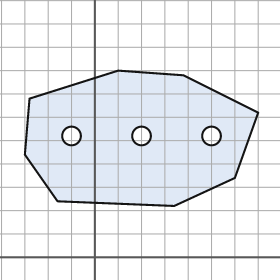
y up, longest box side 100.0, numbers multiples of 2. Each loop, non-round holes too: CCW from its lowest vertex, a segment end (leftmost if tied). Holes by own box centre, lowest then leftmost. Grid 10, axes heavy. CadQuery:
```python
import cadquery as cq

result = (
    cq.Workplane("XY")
    .moveTo(34.0, 22.0)
    .lineTo(60.0, 34.0)
    .lineTo(70.0, 62.0)
    .lineTo(38.0, 78.0)
    .lineTo(10.0, 80.0)
    .lineTo(-28.0, 68.0)
    .lineTo(-30.0, 44.0)
    .lineTo(-16.0, 24.0)
    .close()
    .moveTo(-10.0, 52.0)
    .circle(4.0)
    .moveTo(20.0, 52.0)
    .circle(4.0)
    .moveTo(50.0, 52.0)
    .circle(4.0)
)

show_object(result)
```